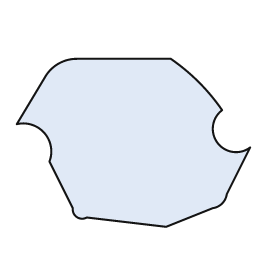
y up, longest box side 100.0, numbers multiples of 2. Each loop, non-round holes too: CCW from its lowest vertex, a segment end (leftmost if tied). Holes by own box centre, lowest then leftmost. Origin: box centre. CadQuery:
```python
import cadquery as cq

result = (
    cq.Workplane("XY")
    .moveTo(14.0, -36.0)
    .lineTo(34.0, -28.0)
    .threePointArc((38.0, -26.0), (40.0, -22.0))
    .lineTo(50.0, -2.0)
    .threePointArc((36.0, 0.0), (38.0, 14.0))
    .threePointArc((28.0, 26.0), (16.0, 36.0))
    .lineTo(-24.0, 36.0)
    .threePointArc((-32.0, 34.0), (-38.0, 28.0))
    .lineTo(-50.0, 8.0)
    .threePointArc((-38.0, 4.0), (-36.0, -8.0))
    .lineTo(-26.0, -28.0)
    .threePointArc((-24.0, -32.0), (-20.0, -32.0))
    .close()
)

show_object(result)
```